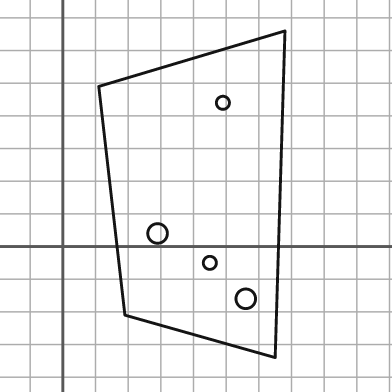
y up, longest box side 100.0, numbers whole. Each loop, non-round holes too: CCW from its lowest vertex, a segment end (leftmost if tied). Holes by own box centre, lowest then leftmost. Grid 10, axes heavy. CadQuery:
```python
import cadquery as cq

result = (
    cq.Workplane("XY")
    .moveTo(65.0, -34.0)
    .lineTo(68.0, 66.0)
    .lineTo(11.0, 49.0)
    .lineTo(19.0, -21.0)
    .close()
    .moveTo(56.0, -16.0)
    .circle(3.0)
    .moveTo(45.0, -5.0)
    .circle(2.0)
    .moveTo(29.0, 4.0)
    .circle(3.0)
    .moveTo(49.0, 44.0)
    .circle(2.0)
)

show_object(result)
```